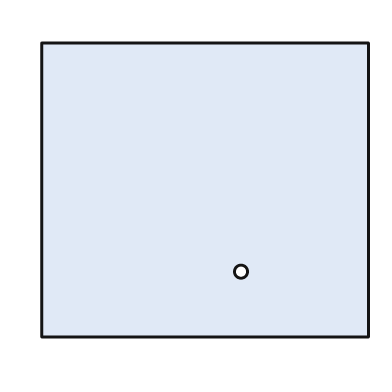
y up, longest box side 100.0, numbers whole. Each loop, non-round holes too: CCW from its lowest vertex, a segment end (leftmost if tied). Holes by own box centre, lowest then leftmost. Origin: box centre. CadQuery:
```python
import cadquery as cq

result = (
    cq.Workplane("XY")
    .moveTo(-50.0, -45.0)
    .lineTo(50.0, -45.0)
    .lineTo(50.0, 45.0)
    .lineTo(-50.0, 45.0)
    .close()
    .moveTo(11.0, -25.0)
    .circle(2.0)
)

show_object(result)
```